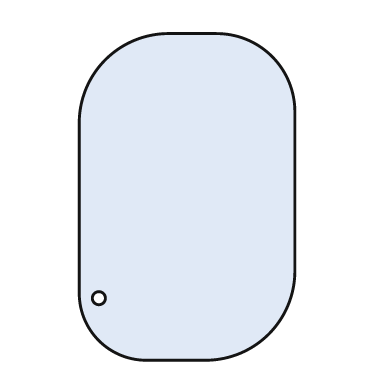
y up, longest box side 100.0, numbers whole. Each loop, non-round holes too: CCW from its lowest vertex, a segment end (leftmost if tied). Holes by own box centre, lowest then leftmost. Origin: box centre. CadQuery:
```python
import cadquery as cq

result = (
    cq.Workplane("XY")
    .moveTo(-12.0, -50.0)
    .lineTo(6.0, -50.0)
    .threePointArc((25.0, -42.0), (33.0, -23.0))
    .lineTo(33.0, 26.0)
    .threePointArc((26.0, 43.0), (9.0, 50.0))
    .lineTo(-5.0, 50.0)
    .threePointArc((-25.0, 42.0), (-33.0, 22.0))
    .lineTo(-33.0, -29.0)
    .threePointArc((-27.0, -44.0), (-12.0, -50.0))
    .close()
    .moveTo(-27.0, -31.0)
    .circle(2.0)
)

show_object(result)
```